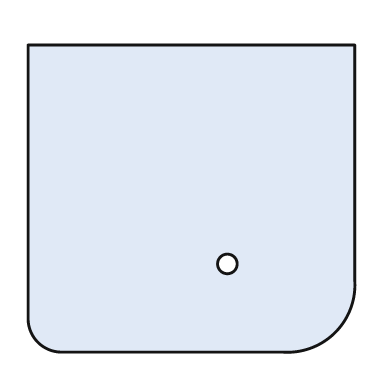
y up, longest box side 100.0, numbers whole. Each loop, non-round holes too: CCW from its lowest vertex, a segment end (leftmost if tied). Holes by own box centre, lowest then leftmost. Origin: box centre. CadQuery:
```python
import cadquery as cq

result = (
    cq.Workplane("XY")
    .moveTo(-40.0, -47.0)
    .lineTo(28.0, -47.0)
    .threePointArc((44.0, -41.0), (50.0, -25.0))
    .lineTo(50.0, 47.0)
    .lineTo(-50.0, 47.0)
    .lineTo(-50.0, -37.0)
    .threePointArc((-47.0, -44.0), (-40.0, -47.0))
    .close()
    .moveTo(11.0, -20.0)
    .circle(3.0)
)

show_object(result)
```